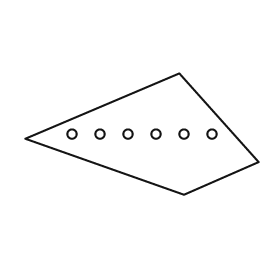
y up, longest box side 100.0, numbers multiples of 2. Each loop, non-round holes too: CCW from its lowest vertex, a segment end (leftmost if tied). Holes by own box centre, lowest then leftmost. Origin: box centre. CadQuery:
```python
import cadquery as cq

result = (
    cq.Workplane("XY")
    .moveTo(18.0, -26.0)
    .lineTo(50.0, -12.0)
    .lineTo(16.0, 26.0)
    .lineTo(-50.0, -2.0)
    .close()
    .moveTo(-30.0, 0.0)
    .circle(2.0)
    .moveTo(-18.0, 0.0)
    .circle(2.0)
    .moveTo(-6.0, 0.0)
    .circle(2.0)
    .moveTo(6.0, 0.0)
    .circle(2.0)
    .moveTo(18.0, 0.0)
    .circle(2.0)
    .moveTo(30.0, 0.0)
    .circle(2.0)
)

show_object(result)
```